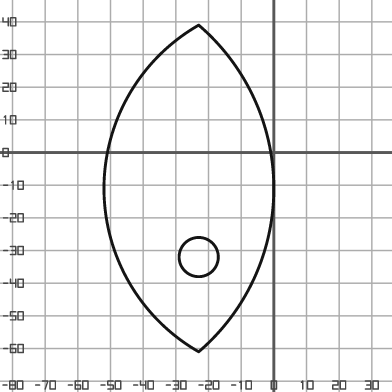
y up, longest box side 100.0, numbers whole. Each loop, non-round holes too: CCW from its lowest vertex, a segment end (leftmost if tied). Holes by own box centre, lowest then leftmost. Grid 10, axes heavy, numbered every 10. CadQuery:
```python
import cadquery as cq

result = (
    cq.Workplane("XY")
    .moveTo(-23.0, -61.0)
    .threePointArc((0.0, -11.0), (-23.0, 39.0))
    .threePointArc((-52.0, -11.0), (-23.0, -61.0))
    .close()
    .moveTo(-23.0, -32.0)
    .circle(6.0)
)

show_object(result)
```